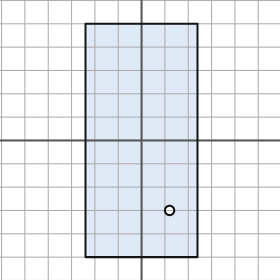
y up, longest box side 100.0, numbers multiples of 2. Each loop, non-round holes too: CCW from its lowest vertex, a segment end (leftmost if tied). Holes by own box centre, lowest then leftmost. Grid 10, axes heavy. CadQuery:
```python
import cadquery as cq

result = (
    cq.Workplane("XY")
    .moveTo(-24.0, -50.0)
    .lineTo(24.0, -50.0)
    .lineTo(24.0, 50.0)
    .lineTo(-24.0, 50.0)
    .close()
    .moveTo(12.0, -30.0)
    .circle(2.0)
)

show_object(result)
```